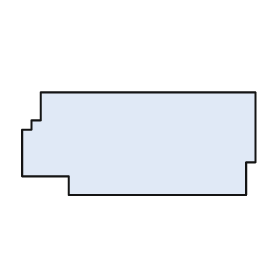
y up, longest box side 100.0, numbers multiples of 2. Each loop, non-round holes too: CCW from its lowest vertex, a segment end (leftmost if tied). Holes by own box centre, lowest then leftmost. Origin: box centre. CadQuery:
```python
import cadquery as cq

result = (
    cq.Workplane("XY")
    .moveTo(-30.0, -22.0)
    .lineTo(46.0, -22.0)
    .lineTo(46.0, -8.0)
    .lineTo(50.0, -8.0)
    .lineTo(50.0, 22.0)
    .lineTo(-42.0, 22.0)
    .lineTo(-42.0, 10.0)
    .lineTo(-46.0, 10.0)
    .lineTo(-46.0, 6.0)
    .lineTo(-50.0, 6.0)
    .lineTo(-50.0, -14.0)
    .lineTo(-30.0, -14.0)
    .close()
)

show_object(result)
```